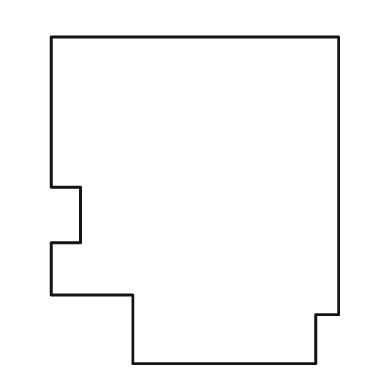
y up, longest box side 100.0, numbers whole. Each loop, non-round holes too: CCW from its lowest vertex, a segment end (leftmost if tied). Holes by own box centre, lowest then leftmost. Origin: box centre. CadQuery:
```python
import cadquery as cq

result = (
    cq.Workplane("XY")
    .moveTo(-19.0, -50.0)
    .lineTo(37.0, -50.0)
    .lineTo(37.0, -35.0)
    .lineTo(44.0, -35.0)
    .lineTo(44.0, 50.0)
    .lineTo(-44.0, 50.0)
    .lineTo(-44.0, 4.0)
    .lineTo(-35.0, 4.0)
    .lineTo(-35.0, -13.0)
    .lineTo(-44.0, -13.0)
    .lineTo(-44.0, -29.0)
    .lineTo(-19.0, -29.0)
    .close()
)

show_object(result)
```